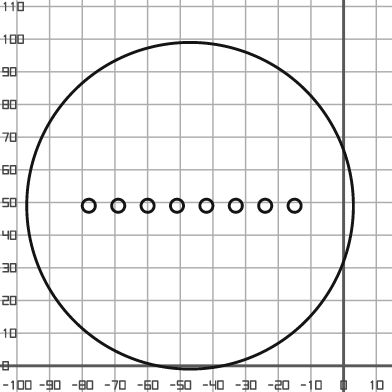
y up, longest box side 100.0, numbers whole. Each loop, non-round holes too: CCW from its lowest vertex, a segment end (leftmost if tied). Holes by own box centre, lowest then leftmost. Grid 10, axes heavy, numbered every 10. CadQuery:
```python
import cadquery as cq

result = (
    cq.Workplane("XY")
    .moveTo(-47.0, 49.0)
    .circle(50.0)
    .moveTo(-78.0, 49.0)
    .circle(2.0)
    .moveTo(-69.0, 49.0)
    .circle(2.0)
    .moveTo(-60.0, 49.0)
    .circle(2.0)
    .moveTo(-51.0, 49.0)
    .circle(2.0)
    .moveTo(-42.0, 49.0)
    .circle(2.0)
    .moveTo(-33.0, 49.0)
    .circle(2.0)
    .moveTo(-24.0, 49.0)
    .circle(2.0)
    .moveTo(-15.0, 49.0)
    .circle(2.0)
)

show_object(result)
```